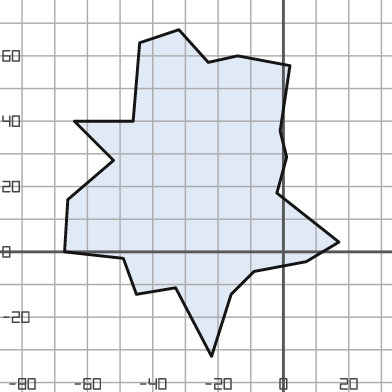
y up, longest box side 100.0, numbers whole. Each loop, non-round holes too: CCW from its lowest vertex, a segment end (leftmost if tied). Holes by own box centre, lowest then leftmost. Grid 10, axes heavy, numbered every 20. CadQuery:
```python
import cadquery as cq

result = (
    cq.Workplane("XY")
    .moveTo(-22.0, -32.0)
    .lineTo(-16.0, -13.0)
    .lineTo(-9.0, -6.0)
    .lineTo(7.0, -3.0)
    .lineTo(17.0, 3.0)
    .lineTo(-2.0, 18.0)
    .lineTo(1.0, 29.0)
    .lineTo(-1.0, 37.0)
    .lineTo(2.0, 57.0)
    .lineTo(-14.0, 60.0)
    .lineTo(-23.0, 58.0)
    .lineTo(-32.0, 68.0)
    .lineTo(-44.0, 64.0)
    .lineTo(-46.0, 40.0)
    .lineTo(-64.0, 40.0)
    .lineTo(-52.0, 28.0)
    .lineTo(-66.0, 16.0)
    .lineTo(-67.0, 0.0)
    .lineTo(-49.0, -2.0)
    .lineTo(-45.0, -13.0)
    .lineTo(-33.0, -11.0)
    .close()
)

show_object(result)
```